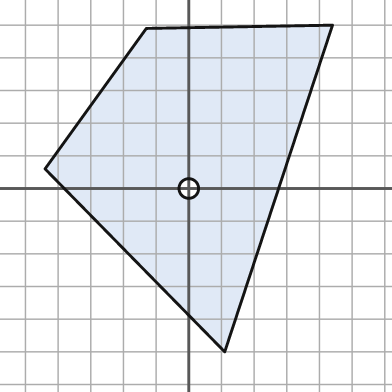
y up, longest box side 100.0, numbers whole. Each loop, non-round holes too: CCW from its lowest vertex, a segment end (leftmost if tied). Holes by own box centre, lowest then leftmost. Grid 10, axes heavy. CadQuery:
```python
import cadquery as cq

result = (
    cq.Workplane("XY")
    .moveTo(11.0, -50.0)
    .lineTo(44.0, 50.0)
    .lineTo(-13.0, 49.0)
    .lineTo(-44.0, 6.0)
    .close()
    .moveTo(0.0, 0.0)
    .circle(3.0)
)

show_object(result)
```